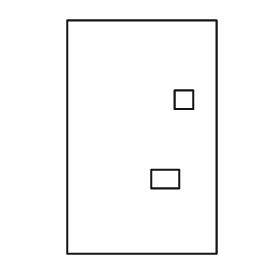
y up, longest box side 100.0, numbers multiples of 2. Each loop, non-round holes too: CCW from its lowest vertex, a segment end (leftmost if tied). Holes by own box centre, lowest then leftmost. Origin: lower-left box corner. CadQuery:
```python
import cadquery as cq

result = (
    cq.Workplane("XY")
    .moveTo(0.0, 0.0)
    .lineTo(64.0, 0.0)
    .lineTo(64.0, 100.0)
    .lineTo(0.0, 100.0)
    .close()
    .moveTo(36.0, 28.0)
    .lineTo(48.0, 28.0)
    .lineTo(48.0, 36.0)
    .lineTo(36.0, 36.0)
    .close()
    .moveTo(46.0, 62.0)
    .lineTo(54.0, 62.0)
    .lineTo(54.0, 70.0)
    .lineTo(46.0, 70.0)
    .close()
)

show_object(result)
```